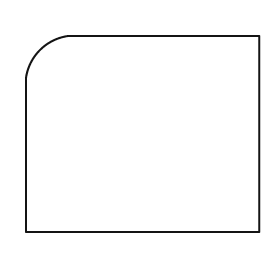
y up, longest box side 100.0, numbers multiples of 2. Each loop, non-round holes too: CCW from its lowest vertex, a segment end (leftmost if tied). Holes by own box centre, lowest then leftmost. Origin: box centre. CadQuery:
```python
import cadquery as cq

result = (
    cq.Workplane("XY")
    .moveTo(-50.0, -42.0)
    .lineTo(50.0, -42.0)
    .lineTo(50.0, 42.0)
    .lineTo(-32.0, 42.0)
    .threePointArc((-44.0, 36.0), (-50.0, 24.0))
    .close()
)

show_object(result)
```